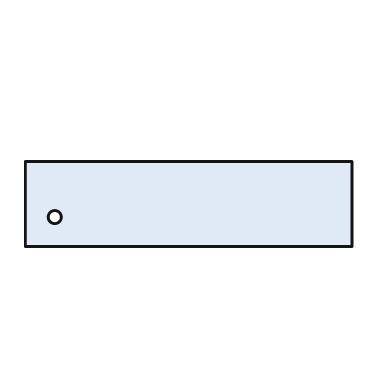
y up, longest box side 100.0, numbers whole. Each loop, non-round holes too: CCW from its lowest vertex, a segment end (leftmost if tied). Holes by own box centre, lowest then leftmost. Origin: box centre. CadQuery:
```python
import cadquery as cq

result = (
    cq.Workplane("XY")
    .moveTo(-50.0, -13.0)
    .lineTo(50.0, -13.0)
    .lineTo(50.0, 13.0)
    .lineTo(-50.0, 13.0)
    .close()
    .moveTo(-41.0, -4.0)
    .circle(2.0)
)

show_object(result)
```